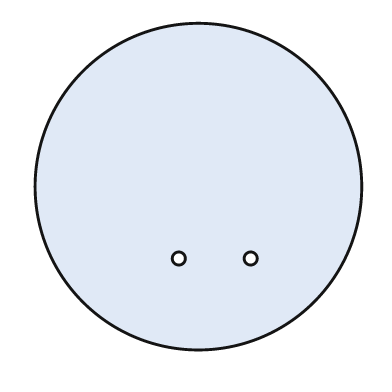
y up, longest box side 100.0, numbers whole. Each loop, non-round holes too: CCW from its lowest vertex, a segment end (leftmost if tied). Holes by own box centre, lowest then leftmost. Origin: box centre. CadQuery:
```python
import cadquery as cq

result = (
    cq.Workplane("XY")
    .moveTo(0.0, 0.0)
    .circle(50.0)
    .moveTo(-6.0, -22.0)
    .circle(2.0)
    .moveTo(16.0, -22.0)
    .circle(2.0)
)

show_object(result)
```